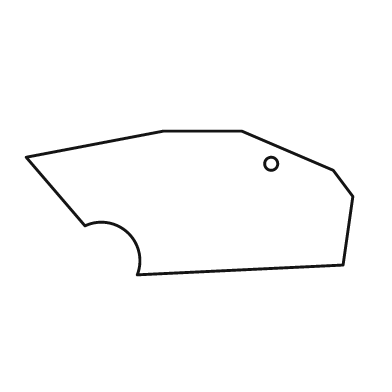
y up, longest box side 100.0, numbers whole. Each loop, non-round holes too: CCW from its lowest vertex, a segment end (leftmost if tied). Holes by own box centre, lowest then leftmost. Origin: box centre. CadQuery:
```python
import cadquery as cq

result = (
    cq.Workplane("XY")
    .moveTo(-16.0, -22.0)
    .lineTo(47.0, -19.0)
    .lineTo(50.0, 2.0)
    .lineTo(44.0, 10.0)
    .lineTo(16.0, 22.0)
    .lineTo(-8.0, 22.0)
    .lineTo(-50.0, 14.0)
    .lineTo(-32.0, -7.0)
    .threePointArc((-19.0, -9.0), (-16.0, -22.0))
    .close()
    .moveTo(25.0, 12.0)
    .circle(2.0)
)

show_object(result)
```